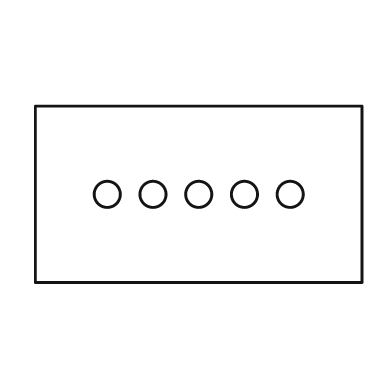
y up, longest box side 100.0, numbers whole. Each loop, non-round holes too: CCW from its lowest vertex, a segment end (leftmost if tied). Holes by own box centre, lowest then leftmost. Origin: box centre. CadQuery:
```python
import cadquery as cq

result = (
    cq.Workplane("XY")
    .moveTo(-50.0, -27.0)
    .lineTo(50.0, -27.0)
    .lineTo(50.0, 27.0)
    .lineTo(-50.0, 27.0)
    .close()
    .moveTo(-28.0, 0.0)
    .circle(4.0)
    .moveTo(-14.0, 0.0)
    .circle(4.0)
    .moveTo(0.0, 0.0)
    .circle(4.0)
    .moveTo(14.0, 0.0)
    .circle(4.0)
    .moveTo(28.0, 0.0)
    .circle(4.0)
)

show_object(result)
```